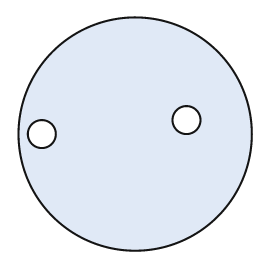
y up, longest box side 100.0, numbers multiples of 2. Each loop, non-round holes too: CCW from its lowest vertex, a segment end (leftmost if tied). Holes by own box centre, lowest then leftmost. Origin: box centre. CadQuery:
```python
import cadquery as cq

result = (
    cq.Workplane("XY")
    .moveTo(0.0, 0.0)
    .circle(50.0)
    .moveTo(-40.0, 0.0)
    .circle(6.0)
    .moveTo(22.0, 6.0)
    .circle(6.0)
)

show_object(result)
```